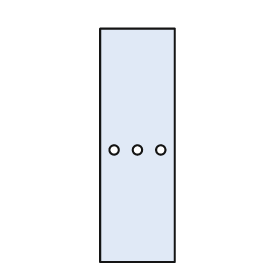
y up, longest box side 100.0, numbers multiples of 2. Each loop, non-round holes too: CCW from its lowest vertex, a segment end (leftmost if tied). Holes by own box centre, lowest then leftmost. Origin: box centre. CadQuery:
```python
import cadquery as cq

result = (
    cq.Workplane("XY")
    .moveTo(-16.0, -50.0)
    .lineTo(16.0, -50.0)
    .lineTo(16.0, 50.0)
    .lineTo(-16.0, 50.0)
    .close()
    .moveTo(-10.0, -2.0)
    .circle(2.0)
    .moveTo(0.0, -2.0)
    .circle(2.0)
    .moveTo(10.0, -2.0)
    .circle(2.0)
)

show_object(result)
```